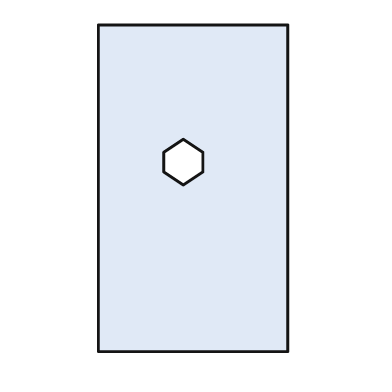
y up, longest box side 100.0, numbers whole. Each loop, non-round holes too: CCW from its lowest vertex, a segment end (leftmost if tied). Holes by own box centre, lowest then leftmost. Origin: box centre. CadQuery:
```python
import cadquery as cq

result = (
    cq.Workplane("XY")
    .moveTo(-29.0, -50.0)
    .lineTo(29.0, -50.0)
    .lineTo(29.0, 50.0)
    .lineTo(-29.0, 50.0)
    .close()
    .moveTo(-3.0, 1.0)
    .lineTo(3.0, 5.0)
    .lineTo(3.0, 11.0)
    .lineTo(-3.0, 15.0)
    .lineTo(-9.0, 11.0)
    .lineTo(-9.0, 5.0)
    .close()
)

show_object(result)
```